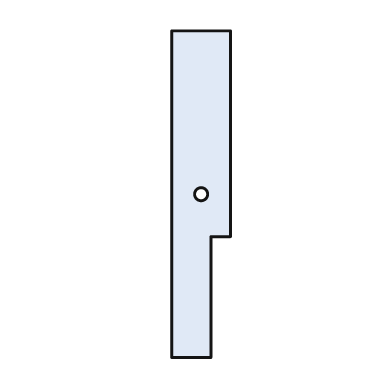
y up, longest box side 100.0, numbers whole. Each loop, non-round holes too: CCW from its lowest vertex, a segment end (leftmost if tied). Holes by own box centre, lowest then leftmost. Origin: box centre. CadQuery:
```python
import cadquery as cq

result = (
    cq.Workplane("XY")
    .moveTo(-9.0, -50.0)
    .lineTo(3.0, -50.0)
    .lineTo(3.0, -13.0)
    .lineTo(9.0, -13.0)
    .lineTo(9.0, 50.0)
    .lineTo(-9.0, 50.0)
    .close()
    .moveTo(0.0, 0.0)
    .circle(2.0)
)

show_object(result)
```